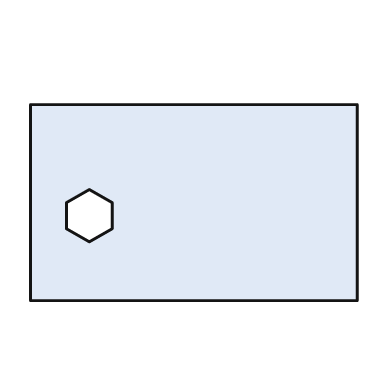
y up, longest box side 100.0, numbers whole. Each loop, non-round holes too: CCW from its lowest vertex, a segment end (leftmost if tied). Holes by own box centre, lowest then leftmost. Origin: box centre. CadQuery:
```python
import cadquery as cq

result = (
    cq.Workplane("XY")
    .moveTo(-50.0, -30.0)
    .lineTo(50.0, -30.0)
    .lineTo(50.0, 30.0)
    .lineTo(-50.0, 30.0)
    .close()
    .moveTo(-32.0, -12.0)
    .lineTo(-25.0, -8.0)
    .lineTo(-25.0, 0.0)
    .lineTo(-32.0, 4.0)
    .lineTo(-39.0, 0.0)
    .lineTo(-39.0, -8.0)
    .close()
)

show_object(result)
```